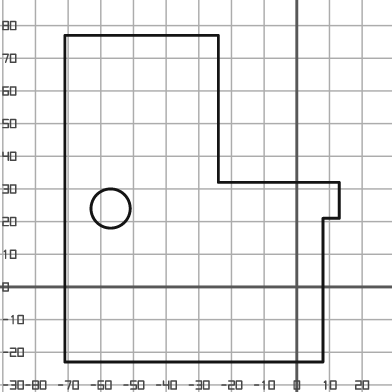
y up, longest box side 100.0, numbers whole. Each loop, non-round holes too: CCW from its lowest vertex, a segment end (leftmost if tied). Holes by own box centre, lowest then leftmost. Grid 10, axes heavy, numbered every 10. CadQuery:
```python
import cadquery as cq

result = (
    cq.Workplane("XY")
    .moveTo(-71.0, -23.0)
    .lineTo(8.0, -23.0)
    .lineTo(8.0, 21.0)
    .lineTo(13.0, 21.0)
    .lineTo(13.0, 32.0)
    .lineTo(-24.0, 32.0)
    .lineTo(-24.0, 77.0)
    .lineTo(-71.0, 77.0)
    .close()
    .moveTo(-57.0, 24.0)
    .circle(6.0)
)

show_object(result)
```